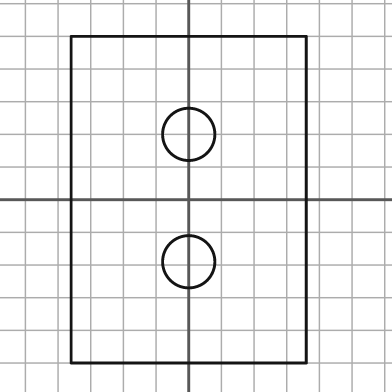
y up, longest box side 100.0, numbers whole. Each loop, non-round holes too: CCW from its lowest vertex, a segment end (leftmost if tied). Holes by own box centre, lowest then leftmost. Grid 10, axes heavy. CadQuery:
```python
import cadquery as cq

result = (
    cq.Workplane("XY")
    .moveTo(-36.0, -50.0)
    .lineTo(36.0, -50.0)
    .lineTo(36.0, 50.0)
    .lineTo(-36.0, 50.0)
    .close()
    .moveTo(0.0, -19.0)
    .circle(8.0)
    .moveTo(0.0, 20.0)
    .circle(8.0)
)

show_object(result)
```